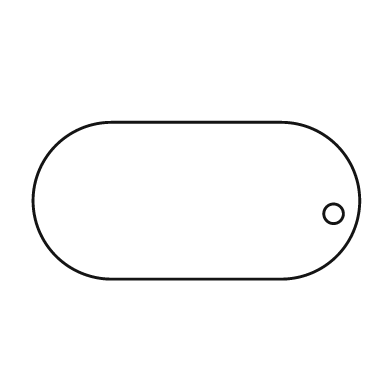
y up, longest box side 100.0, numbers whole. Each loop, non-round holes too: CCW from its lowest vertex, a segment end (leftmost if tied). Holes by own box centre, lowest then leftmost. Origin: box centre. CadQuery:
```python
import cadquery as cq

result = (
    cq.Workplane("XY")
    .moveTo(-26.0, -24.0)
    .lineTo(26.0, -24.0)
    .threePointArc((50.0, 0.0), (26.0, 24.0))
    .lineTo(-26.0, 24.0)
    .threePointArc((-50.0, 0.0), (-26.0, -24.0))
    .close()
    .moveTo(42.0, -4.0)
    .circle(3.0)
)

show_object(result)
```